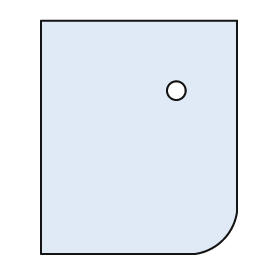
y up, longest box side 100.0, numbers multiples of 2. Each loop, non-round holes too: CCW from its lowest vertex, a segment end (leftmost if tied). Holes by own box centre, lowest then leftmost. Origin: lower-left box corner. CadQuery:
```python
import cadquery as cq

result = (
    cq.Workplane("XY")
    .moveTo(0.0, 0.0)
    .lineTo(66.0, 0.0)
    .threePointArc((78.0, 6.0), (84.0, 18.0))
    .lineTo(84.0, 100.0)
    .lineTo(0.0, 100.0)
    .close()
    .moveTo(58.0, 70.0)
    .circle(4.0)
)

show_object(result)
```